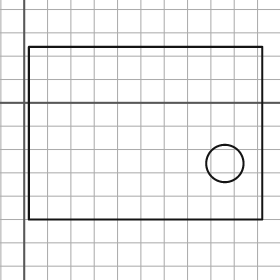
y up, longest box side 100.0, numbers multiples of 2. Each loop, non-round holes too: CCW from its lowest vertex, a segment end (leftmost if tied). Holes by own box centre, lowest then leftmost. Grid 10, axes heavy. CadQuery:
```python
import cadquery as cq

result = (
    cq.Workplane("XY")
    .moveTo(2.0, -50.0)
    .lineTo(102.0, -50.0)
    .lineTo(102.0, 24.0)
    .lineTo(2.0, 24.0)
    .close()
    .moveTo(86.0, -26.0)
    .circle(8.0)
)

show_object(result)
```